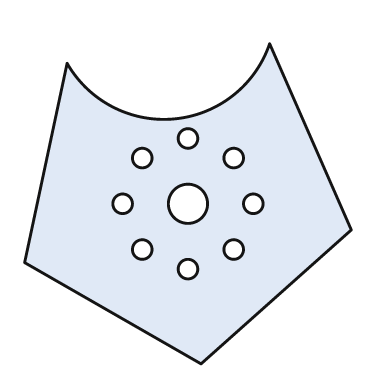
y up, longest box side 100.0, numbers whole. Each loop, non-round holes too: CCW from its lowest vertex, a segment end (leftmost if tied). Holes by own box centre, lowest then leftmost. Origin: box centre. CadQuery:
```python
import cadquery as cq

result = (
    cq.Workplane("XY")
    .moveTo(4.0, -49.0)
    .lineTo(50.0, -8.0)
    .lineTo(25.0, 49.0)
    .threePointArc((-4.0, 26.0), (-37.0, 43.0))
    .lineTo(-50.0, -18.0)
    .close()
    .moveTo(0.0, -20.0)
    .circle(3.0)
    .moveTo(-14.0, -14.0)
    .circle(3.0)
    .moveTo(14.0, -14.0)
    .circle(3.0)
    .moveTo(-20.0, 0.0)
    .circle(3.0)
    .moveTo(0.0, 0.0)
    .circle(6.0)
    .moveTo(20.0, 0.0)
    .circle(3.0)
    .moveTo(-14.0, 14.0)
    .circle(3.0)
    .moveTo(14.0, 14.0)
    .circle(3.0)
    .moveTo(0.0, 20.0)
    .circle(3.0)
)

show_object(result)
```